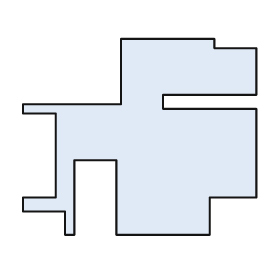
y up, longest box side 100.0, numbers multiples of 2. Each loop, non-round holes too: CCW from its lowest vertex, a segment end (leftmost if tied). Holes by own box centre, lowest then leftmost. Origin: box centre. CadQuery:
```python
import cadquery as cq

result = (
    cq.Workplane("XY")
    .moveTo(-32.0, -42.0)
    .lineTo(-28.0, -42.0)
    .lineTo(-28.0, -10.0)
    .lineTo(-10.0, -10.0)
    .lineTo(-10.0, -42.0)
    .lineTo(30.0, -42.0)
    .lineTo(30.0, -26.0)
    .lineTo(50.0, -26.0)
    .lineTo(50.0, 12.0)
    .lineTo(10.0, 12.0)
    .lineTo(10.0, 18.0)
    .lineTo(50.0, 18.0)
    .lineTo(50.0, 38.0)
    .lineTo(32.0, 38.0)
    .lineTo(32.0, 42.0)
    .lineTo(-8.0, 42.0)
    .lineTo(-8.0, 14.0)
    .lineTo(-50.0, 14.0)
    .lineTo(-50.0, 10.0)
    .lineTo(-36.0, 10.0)
    .lineTo(-36.0, -26.0)
    .lineTo(-50.0, -26.0)
    .lineTo(-50.0, -32.0)
    .lineTo(-32.0, -32.0)
    .close()
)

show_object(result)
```